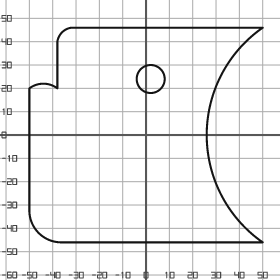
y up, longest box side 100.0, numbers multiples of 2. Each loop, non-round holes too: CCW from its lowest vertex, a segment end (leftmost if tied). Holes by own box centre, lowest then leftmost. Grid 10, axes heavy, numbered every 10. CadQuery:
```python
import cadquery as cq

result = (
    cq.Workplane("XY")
    .moveTo(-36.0, -46.0)
    .lineTo(50.0, -46.0)
    .threePointArc((26.0, 0.0), (50.0, 46.0))
    .lineTo(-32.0, 46.0)
    .threePointArc((-36.0, 44.0), (-38.0, 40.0))
    .lineTo(-38.0, 20.0)
    .threePointArc((-44.0, 22.0), (-50.0, 20.0))
    .lineTo(-50.0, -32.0)
    .threePointArc((-46.0, -42.0), (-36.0, -46.0))
    .close()
    .moveTo(2.0, 24.0)
    .circle(6.0)
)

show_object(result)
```